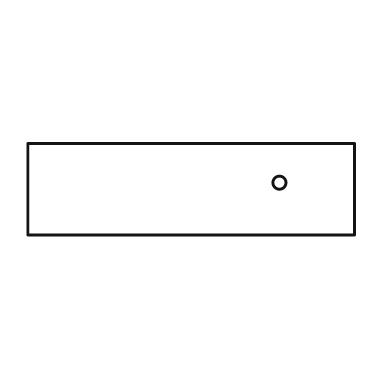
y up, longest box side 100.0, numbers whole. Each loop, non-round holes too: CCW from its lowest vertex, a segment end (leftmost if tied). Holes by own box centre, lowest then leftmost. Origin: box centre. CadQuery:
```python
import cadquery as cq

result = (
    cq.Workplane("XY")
    .moveTo(-50.0, -14.0)
    .lineTo(50.0, -14.0)
    .lineTo(50.0, 14.0)
    .lineTo(-50.0, 14.0)
    .close()
    .moveTo(27.0, 2.0)
    .circle(2.0)
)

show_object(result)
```